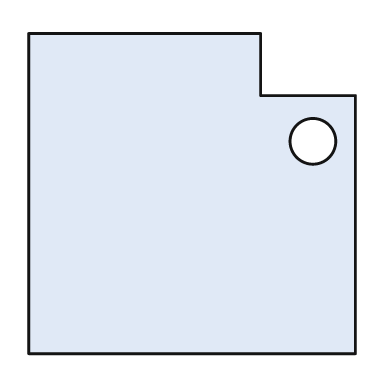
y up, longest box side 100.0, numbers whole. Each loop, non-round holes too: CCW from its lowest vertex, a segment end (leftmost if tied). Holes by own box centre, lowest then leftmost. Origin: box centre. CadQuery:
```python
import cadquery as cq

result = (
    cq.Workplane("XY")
    .moveTo(-50.0, -49.0)
    .lineTo(50.0, -49.0)
    .lineTo(50.0, 30.0)
    .lineTo(21.0, 30.0)
    .lineTo(21.0, 49.0)
    .lineTo(-50.0, 49.0)
    .close()
    .moveTo(37.0, 16.0)
    .circle(7.0)
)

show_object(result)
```